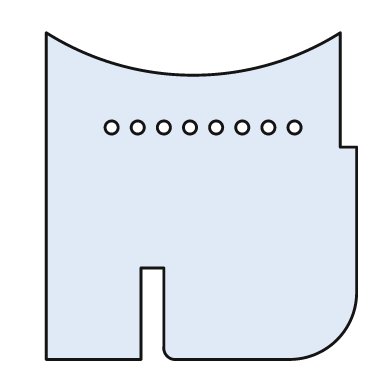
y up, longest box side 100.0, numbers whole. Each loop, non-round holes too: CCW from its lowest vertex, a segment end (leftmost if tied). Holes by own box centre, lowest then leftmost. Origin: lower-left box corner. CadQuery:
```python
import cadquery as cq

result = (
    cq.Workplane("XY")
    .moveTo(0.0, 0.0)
    .lineTo(29.0, 0.0)
    .lineTo(29.0, 28.0)
    .lineTo(36.0, 28.0)
    .lineTo(36.0, 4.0)
    .threePointArc((37.0, 1.0), (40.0, 0.0))
    .lineTo(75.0, 0.0)
    .threePointArc((89.0, 6.0), (95.0, 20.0))
    .lineTo(95.0, 65.0)
    .lineTo(90.0, 65.0)
    .lineTo(90.0, 100.0)
    .threePointArc((45.0, 87.0), (0.0, 100.0))
    .close()
    .moveTo(20.0, 71.0)
    .circle(2.0)
    .moveTo(28.0, 71.0)
    .circle(2.0)
    .moveTo(36.0, 71.0)
    .circle(2.0)
    .moveTo(44.0, 71.0)
    .circle(2.0)
    .moveTo(52.0, 71.0)
    .circle(2.0)
    .moveTo(60.0, 71.0)
    .circle(2.0)
    .moveTo(68.0, 71.0)
    .circle(2.0)
    .moveTo(76.0, 71.0)
    .circle(2.0)
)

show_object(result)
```